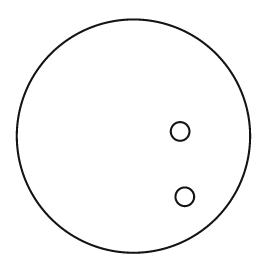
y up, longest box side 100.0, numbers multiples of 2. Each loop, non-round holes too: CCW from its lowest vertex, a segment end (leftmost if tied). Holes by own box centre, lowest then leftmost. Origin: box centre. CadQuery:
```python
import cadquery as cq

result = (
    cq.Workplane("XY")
    .moveTo(0.0, 0.0)
    .circle(50.0)
    .moveTo(22.0, -26.0)
    .circle(4.0)
    .moveTo(20.0, 2.0)
    .circle(4.0)
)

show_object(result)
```